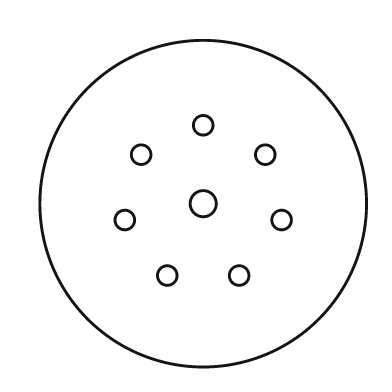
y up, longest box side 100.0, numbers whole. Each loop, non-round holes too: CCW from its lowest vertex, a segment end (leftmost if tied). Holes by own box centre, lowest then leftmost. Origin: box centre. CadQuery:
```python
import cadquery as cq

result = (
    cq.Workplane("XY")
    .moveTo(0.0, 0.0)
    .circle(50.0)
    .moveTo(-11.0, -22.0)
    .circle(3.0)
    .moveTo(11.0, -22.0)
    .circle(3.0)
    .moveTo(-24.0, -5.0)
    .circle(3.0)
    .moveTo(24.0, -5.0)
    .circle(3.0)
    .moveTo(0.0, 0.0)
    .circle(4.0)
    .moveTo(-19.0, 15.0)
    .circle(3.0)
    .moveTo(19.0, 15.0)
    .circle(3.0)
    .moveTo(0.0, 24.0)
    .circle(3.0)
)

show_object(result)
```